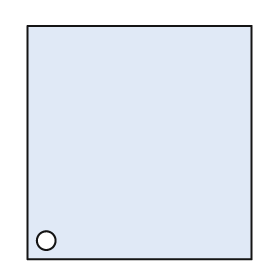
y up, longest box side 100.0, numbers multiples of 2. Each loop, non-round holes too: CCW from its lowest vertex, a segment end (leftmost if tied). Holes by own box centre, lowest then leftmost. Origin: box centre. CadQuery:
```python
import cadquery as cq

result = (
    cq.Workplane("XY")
    .moveTo(-48.0, -50.0)
    .lineTo(48.0, -50.0)
    .lineTo(48.0, 50.0)
    .lineTo(-48.0, 50.0)
    .close()
    .moveTo(-40.0, -42.0)
    .circle(4.0)
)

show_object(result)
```